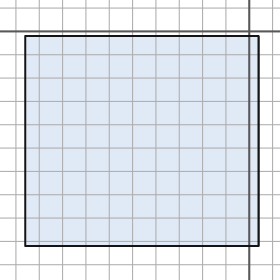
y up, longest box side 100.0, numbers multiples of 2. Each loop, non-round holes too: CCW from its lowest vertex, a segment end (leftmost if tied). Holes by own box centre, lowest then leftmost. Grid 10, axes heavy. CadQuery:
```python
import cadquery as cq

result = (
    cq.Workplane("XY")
    .moveTo(-96.0, -92.0)
    .lineTo(4.0, -92.0)
    .lineTo(4.0, -2.0)
    .lineTo(-96.0, -2.0)
    .close()
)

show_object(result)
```